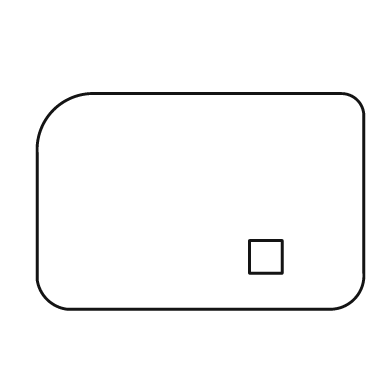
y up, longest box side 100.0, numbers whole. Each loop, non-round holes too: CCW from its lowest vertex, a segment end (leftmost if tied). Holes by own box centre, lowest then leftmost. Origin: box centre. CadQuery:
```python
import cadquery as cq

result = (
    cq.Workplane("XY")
    .moveTo(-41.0, -33.0)
    .lineTo(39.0, -33.0)
    .threePointArc((47.0, -30.0), (50.0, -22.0))
    .lineTo(50.0, 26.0)
    .threePointArc((48.0, 31.0), (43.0, 33.0))
    .lineTo(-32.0, 33.0)
    .threePointArc((-45.0, 28.0), (-50.0, 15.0))
    .lineTo(-50.0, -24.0)
    .threePointArc((-47.0, -30.0), (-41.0, -33.0))
    .close()
    .moveTo(15.0, -22.0)
    .lineTo(25.0, -22.0)
    .lineTo(25.0, -12.0)
    .lineTo(15.0, -12.0)
    .close()
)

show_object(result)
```